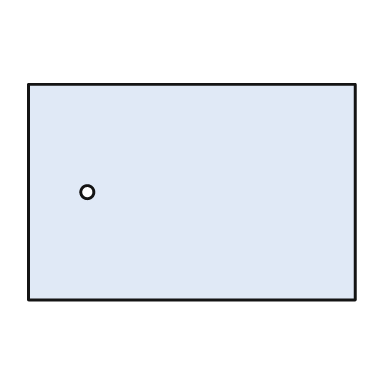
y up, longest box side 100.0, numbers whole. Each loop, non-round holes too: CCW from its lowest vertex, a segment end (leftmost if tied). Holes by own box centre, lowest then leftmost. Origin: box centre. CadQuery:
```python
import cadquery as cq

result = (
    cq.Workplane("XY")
    .moveTo(-50.0, -33.0)
    .lineTo(50.0, -33.0)
    .lineTo(50.0, 33.0)
    .lineTo(-50.0, 33.0)
    .close()
    .moveTo(-32.0, 0.0)
    .circle(2.0)
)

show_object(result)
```